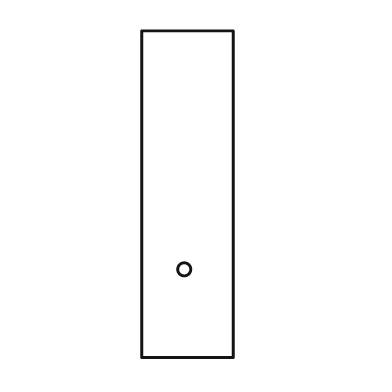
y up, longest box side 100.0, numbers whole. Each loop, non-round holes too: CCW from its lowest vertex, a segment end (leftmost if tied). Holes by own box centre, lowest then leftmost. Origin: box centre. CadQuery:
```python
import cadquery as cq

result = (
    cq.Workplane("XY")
    .moveTo(-14.0, -50.0)
    .lineTo(14.0, -50.0)
    .lineTo(14.0, 50.0)
    .lineTo(-14.0, 50.0)
    .close()
    .moveTo(-1.0, -23.0)
    .circle(2.0)
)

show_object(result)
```